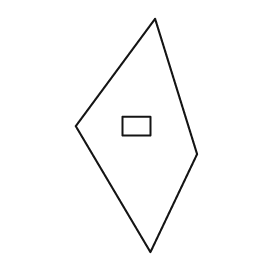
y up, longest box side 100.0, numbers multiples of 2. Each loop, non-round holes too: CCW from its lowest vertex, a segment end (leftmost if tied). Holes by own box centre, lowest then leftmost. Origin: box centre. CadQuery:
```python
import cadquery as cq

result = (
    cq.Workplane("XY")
    .moveTo(6.0, -50.0)
    .lineTo(26.0, -8.0)
    .lineTo(8.0, 50.0)
    .lineTo(-26.0, 4.0)
    .close()
    .moveTo(-6.0, 0.0)
    .lineTo(6.0, 0.0)
    .lineTo(6.0, 8.0)
    .lineTo(-6.0, 8.0)
    .close()
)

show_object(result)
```